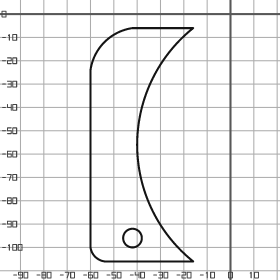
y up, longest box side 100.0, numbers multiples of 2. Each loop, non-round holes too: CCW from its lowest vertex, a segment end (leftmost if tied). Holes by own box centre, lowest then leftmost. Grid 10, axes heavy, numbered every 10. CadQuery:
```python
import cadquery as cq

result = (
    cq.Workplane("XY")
    .moveTo(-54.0, -106.0)
    .lineTo(-16.0, -106.0)
    .threePointArc((-40.0, -56.0), (-16.0, -6.0))
    .lineTo(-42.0, -6.0)
    .threePointArc((-54.0, -12.0), (-60.0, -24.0))
    .lineTo(-60.0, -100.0)
    .threePointArc((-58.0, -104.0), (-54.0, -106.0))
    .close()
    .moveTo(-42.0, -96.0)
    .circle(4.0)
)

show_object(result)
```